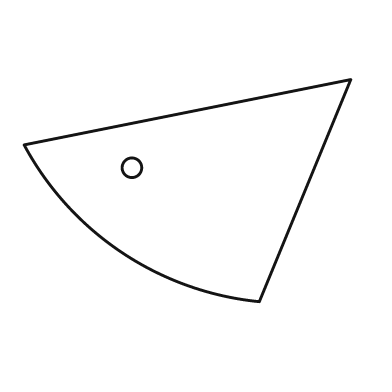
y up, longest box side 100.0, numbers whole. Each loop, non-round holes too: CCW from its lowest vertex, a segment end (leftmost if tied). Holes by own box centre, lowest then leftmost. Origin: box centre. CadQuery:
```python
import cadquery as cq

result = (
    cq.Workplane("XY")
    .moveTo(22.0, -34.0)
    .lineTo(50.0, 34.0)
    .lineTo(-50.0, 14.0)
    .threePointArc((-20.0, -19.0), (22.0, -34.0))
    .close()
    .moveTo(-17.0, 7.0)
    .circle(3.0)
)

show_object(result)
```